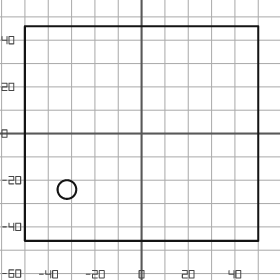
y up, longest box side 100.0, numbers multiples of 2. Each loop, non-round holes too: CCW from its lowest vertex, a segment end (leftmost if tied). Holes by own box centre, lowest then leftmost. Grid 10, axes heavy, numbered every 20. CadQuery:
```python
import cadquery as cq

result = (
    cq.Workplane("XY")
    .moveTo(-50.0, -46.0)
    .lineTo(50.0, -46.0)
    .lineTo(50.0, 46.0)
    .lineTo(-50.0, 46.0)
    .close()
    .moveTo(-32.0, -24.0)
    .circle(4.0)
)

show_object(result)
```